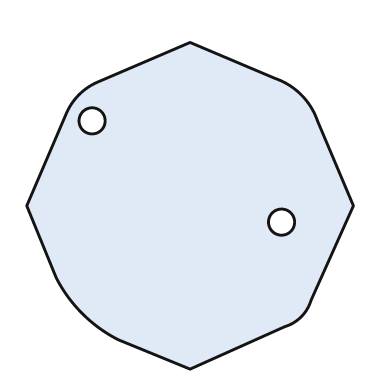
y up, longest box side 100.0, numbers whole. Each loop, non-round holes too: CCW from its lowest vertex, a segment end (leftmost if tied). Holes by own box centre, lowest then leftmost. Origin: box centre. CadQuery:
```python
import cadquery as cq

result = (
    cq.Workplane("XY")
    .moveTo(0.0, -50.0)
    .lineTo(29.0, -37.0)
    .threePointArc((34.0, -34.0), (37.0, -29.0))
    .lineTo(50.0, 0.0)
    .lineTo(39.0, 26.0)
    .threePointArc((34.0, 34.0), (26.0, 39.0))
    .lineTo(0.0, 50.0)
    .lineTo(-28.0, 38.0)
    .threePointArc((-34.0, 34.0), (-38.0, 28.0))
    .lineTo(-50.0, 0.0)
    .lineTo(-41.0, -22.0)
    .threePointArc((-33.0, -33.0), (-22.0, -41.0))
    .close()
    .moveTo(28.0, -5.0)
    .circle(4.0)
    .moveTo(-30.0, 26.0)
    .circle(4.0)
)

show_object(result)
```